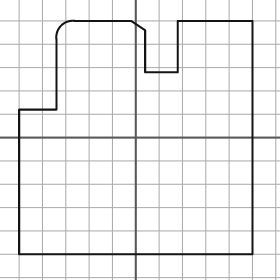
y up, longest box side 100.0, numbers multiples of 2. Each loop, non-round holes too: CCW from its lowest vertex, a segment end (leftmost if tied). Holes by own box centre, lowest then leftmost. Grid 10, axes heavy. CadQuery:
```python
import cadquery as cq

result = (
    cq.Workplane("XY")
    .moveTo(-50.0, -50.0)
    .lineTo(50.0, -50.0)
    .lineTo(50.0, 50.0)
    .lineTo(18.0, 50.0)
    .lineTo(18.0, 28.0)
    .lineTo(4.0, 28.0)
    .lineTo(4.0, 46.0)
    .lineTo(-2.0, 50.0)
    .lineTo(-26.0, 50.0)
    .threePointArc((-32.0, 48.0), (-34.0, 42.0))
    .lineTo(-34.0, 12.0)
    .lineTo(-50.0, 12.0)
    .close()
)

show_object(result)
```